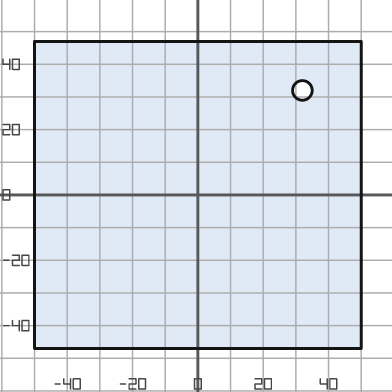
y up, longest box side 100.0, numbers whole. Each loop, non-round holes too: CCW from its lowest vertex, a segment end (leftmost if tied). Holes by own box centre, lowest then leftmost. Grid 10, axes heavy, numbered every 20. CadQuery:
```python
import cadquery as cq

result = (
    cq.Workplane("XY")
    .moveTo(-50.0, -47.0)
    .lineTo(50.0, -47.0)
    .lineTo(50.0, 47.0)
    .lineTo(-50.0, 47.0)
    .close()
    .moveTo(32.0, 32.0)
    .circle(3.0)
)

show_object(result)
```